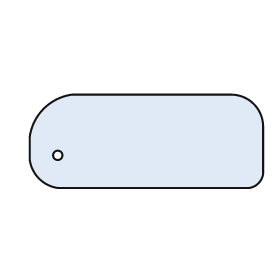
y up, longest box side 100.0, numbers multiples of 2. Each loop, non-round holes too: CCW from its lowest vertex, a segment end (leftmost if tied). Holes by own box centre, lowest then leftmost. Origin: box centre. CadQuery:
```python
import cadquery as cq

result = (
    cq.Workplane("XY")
    .moveTo(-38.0, -20.0)
    .lineTo(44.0, -20.0)
    .threePointArc((48.0, -18.0), (50.0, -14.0))
    .lineTo(50.0, 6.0)
    .threePointArc((46.0, 16.0), (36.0, 20.0))
    .lineTo(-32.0, 20.0)
    .threePointArc((-44.0, 14.0), (-50.0, 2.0))
    .lineTo(-50.0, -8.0)
    .threePointArc((-46.0, -16.0), (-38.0, -20.0))
    .close()
    .moveTo(-38.0, -6.0)
    .circle(2.0)
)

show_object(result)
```